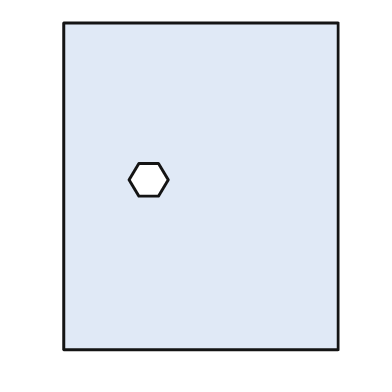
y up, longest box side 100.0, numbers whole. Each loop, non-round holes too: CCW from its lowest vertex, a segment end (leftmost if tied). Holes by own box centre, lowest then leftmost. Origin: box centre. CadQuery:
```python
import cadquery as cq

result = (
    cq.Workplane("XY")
    .moveTo(-42.0, -50.0)
    .lineTo(42.0, -50.0)
    .lineTo(42.0, 50.0)
    .lineTo(-42.0, 50.0)
    .close()
    .moveTo(-19.0, -3.0)
    .lineTo(-13.0, -3.0)
    .lineTo(-10.0, 2.0)
    .lineTo(-13.0, 7.0)
    .lineTo(-19.0, 7.0)
    .lineTo(-22.0, 2.0)
    .close()
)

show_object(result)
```